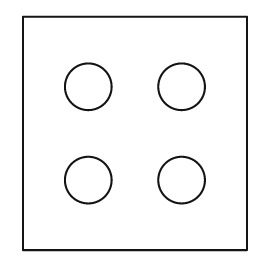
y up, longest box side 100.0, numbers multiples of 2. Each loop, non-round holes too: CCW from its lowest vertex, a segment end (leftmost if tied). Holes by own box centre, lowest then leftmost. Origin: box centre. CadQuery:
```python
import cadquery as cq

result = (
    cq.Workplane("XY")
    .moveTo(-48.0, -50.0)
    .lineTo(48.0, -50.0)
    .lineTo(48.0, 50.0)
    .lineTo(-48.0, 50.0)
    .close()
    .moveTo(-20.0, -20.0)
    .circle(10.0)
    .moveTo(20.0, -20.0)
    .circle(10.0)
    .moveTo(-20.0, 20.0)
    .circle(10.0)
    .moveTo(20.0, 20.0)
    .circle(10.0)
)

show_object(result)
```